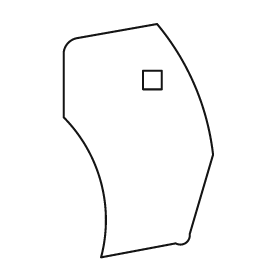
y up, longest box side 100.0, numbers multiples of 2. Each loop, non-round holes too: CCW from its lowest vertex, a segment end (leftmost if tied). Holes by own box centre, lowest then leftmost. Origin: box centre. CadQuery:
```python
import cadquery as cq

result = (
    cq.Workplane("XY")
    .moveTo(-16.0, -50.0)
    .lineTo(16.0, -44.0)
    .threePointArc((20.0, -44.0), (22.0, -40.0))
    .lineTo(32.0, -6.0)
    .threePointArc((24.0, 24.0), (8.0, 50.0))
    .lineTo(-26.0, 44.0)
    .threePointArc((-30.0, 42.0), (-32.0, 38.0))
    .lineTo(-32.0, 10.0)
    .threePointArc((-16.0, -18.0), (-16.0, -50.0))
    .close()
    .moveTo(2.0, 22.0)
    .lineTo(10.0, 22.0)
    .lineTo(10.0, 30.0)
    .lineTo(2.0, 30.0)
    .close()
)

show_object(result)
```